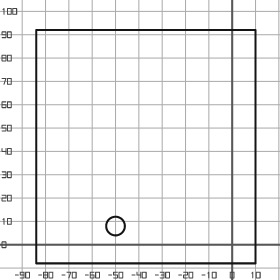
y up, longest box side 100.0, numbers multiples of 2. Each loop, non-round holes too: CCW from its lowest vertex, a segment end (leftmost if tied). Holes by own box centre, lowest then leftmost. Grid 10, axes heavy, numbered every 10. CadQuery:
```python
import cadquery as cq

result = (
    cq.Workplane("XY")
    .moveTo(-84.0, -8.0)
    .lineTo(10.0, -8.0)
    .lineTo(10.0, 92.0)
    .lineTo(-84.0, 92.0)
    .close()
    .moveTo(-50.0, 8.0)
    .circle(4.0)
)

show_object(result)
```